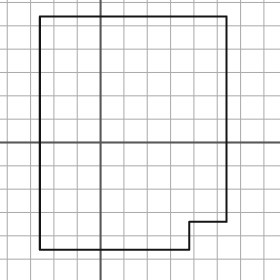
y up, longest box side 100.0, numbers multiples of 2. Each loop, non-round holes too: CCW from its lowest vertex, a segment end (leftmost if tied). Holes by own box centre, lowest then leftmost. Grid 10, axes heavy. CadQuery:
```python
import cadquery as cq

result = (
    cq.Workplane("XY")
    .moveTo(-26.0, -46.0)
    .lineTo(38.0, -46.0)
    .lineTo(38.0, -34.0)
    .lineTo(54.0, -34.0)
    .lineTo(54.0, 54.0)
    .lineTo(-26.0, 54.0)
    .close()
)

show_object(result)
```